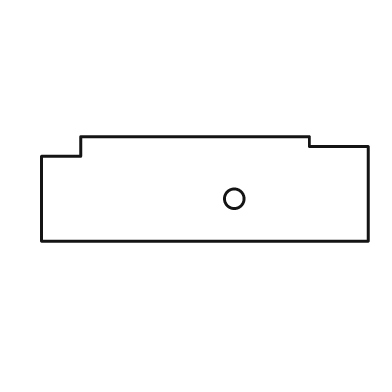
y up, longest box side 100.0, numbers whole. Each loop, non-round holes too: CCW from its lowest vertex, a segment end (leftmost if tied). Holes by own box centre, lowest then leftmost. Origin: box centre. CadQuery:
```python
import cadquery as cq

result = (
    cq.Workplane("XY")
    .moveTo(-50.0, -16.0)
    .lineTo(50.0, -16.0)
    .lineTo(50.0, 13.0)
    .lineTo(32.0, 13.0)
    .lineTo(32.0, 16.0)
    .lineTo(-38.0, 16.0)
    .lineTo(-38.0, 10.0)
    .lineTo(-50.0, 10.0)
    .close()
    .moveTo(9.0, -3.0)
    .circle(3.0)
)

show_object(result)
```